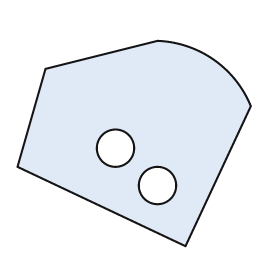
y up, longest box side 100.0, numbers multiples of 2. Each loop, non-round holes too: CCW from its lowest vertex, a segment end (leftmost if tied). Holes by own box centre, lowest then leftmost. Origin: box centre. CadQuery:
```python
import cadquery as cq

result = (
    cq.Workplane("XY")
    .moveTo(22.0, -44.0)
    .lineTo(50.0, 16.0)
    .threePointArc((34.0, 36.0), (10.0, 44.0))
    .lineTo(-38.0, 32.0)
    .lineTo(-50.0, -10.0)
    .close()
    .moveTo(10.0, -18.0)
    .circle(8.0)
    .moveTo(-8.0, -2.0)
    .circle(8.0)
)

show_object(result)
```